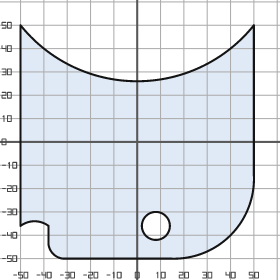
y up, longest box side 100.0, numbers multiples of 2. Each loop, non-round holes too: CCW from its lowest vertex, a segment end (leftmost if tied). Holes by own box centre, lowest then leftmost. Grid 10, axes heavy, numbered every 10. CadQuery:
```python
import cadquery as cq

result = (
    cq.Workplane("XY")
    .moveTo(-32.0, -50.0)
    .lineTo(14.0, -50.0)
    .threePointArc((40.0, -40.0), (50.0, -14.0))
    .lineTo(50.0, 50.0)
    .threePointArc((0.0, 26.0), (-50.0, 50.0))
    .lineTo(-50.0, -36.0)
    .threePointArc((-44.0, -34.0), (-38.0, -36.0))
    .lineTo(-38.0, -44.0)
    .threePointArc((-36.0, -48.0), (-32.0, -50.0))
    .close()
    .moveTo(8.0, -36.0)
    .circle(6.0)
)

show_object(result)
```